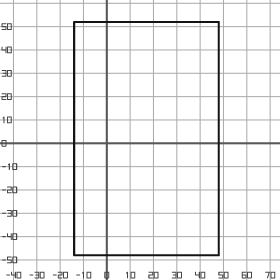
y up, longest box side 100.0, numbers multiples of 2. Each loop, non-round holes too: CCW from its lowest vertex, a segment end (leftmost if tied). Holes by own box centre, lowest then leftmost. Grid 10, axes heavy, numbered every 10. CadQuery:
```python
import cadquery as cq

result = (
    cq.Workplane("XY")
    .moveTo(-14.0, -48.0)
    .lineTo(48.0, -48.0)
    .lineTo(48.0, 52.0)
    .lineTo(-14.0, 52.0)
    .close()
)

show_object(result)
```